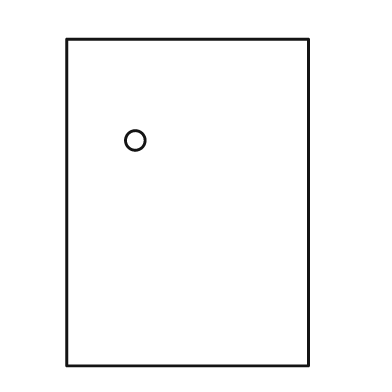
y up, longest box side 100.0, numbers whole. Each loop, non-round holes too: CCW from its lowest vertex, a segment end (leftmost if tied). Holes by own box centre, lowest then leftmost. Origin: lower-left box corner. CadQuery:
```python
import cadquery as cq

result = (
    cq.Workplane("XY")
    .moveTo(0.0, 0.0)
    .lineTo(74.0, 0.0)
    .lineTo(74.0, 100.0)
    .lineTo(0.0, 100.0)
    .close()
    .moveTo(21.0, 69.0)
    .circle(3.0)
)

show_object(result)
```